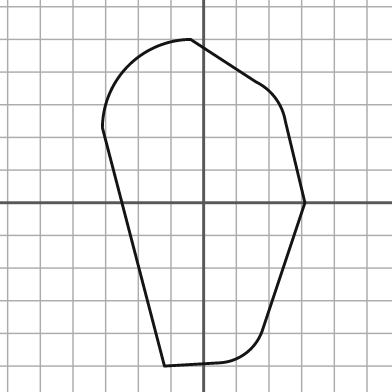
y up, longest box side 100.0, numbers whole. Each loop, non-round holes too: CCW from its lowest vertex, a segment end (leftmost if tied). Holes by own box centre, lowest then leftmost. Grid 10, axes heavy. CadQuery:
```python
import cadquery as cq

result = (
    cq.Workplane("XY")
    .moveTo(-12.0, -50.0)
    .lineTo(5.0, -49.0)
    .threePointArc((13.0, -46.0), (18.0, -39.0))
    .lineTo(31.0, 0.0)
    .lineTo(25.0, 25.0)
    .threePointArc((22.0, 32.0), (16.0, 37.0))
    .lineTo(-4.0, 50.0)
    .threePointArc((-23.0, 42.0), (-31.0, 23.0))
    .close()
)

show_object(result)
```